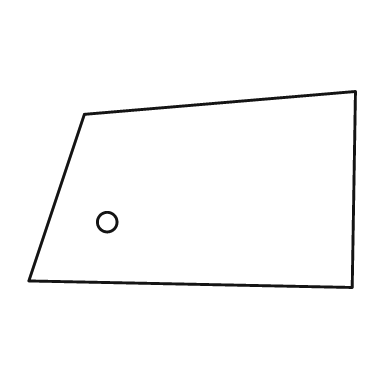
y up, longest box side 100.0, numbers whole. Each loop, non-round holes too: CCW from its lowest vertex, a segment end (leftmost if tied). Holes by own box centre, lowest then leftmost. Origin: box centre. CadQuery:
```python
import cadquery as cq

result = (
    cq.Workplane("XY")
    .moveTo(49.0, -30.0)
    .lineTo(50.0, 30.0)
    .lineTo(-33.0, 23.0)
    .lineTo(-50.0, -28.0)
    .close()
    .moveTo(-26.0, -10.0)
    .circle(3.0)
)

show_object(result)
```